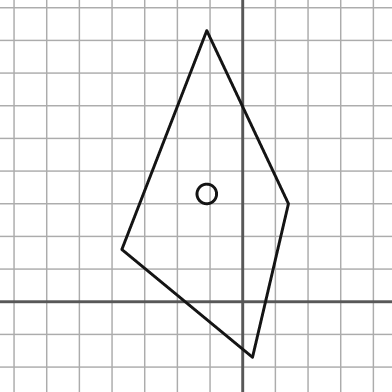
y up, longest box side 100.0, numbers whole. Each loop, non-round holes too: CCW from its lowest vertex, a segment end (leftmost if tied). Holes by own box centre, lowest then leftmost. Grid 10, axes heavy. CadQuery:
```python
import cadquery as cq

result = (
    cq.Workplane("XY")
    .moveTo(3.0, -17.0)
    .lineTo(14.0, 30.0)
    .lineTo(-11.0, 83.0)
    .lineTo(-37.0, 16.0)
    .close()
    .moveTo(-11.0, 33.0)
    .circle(3.0)
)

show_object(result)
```